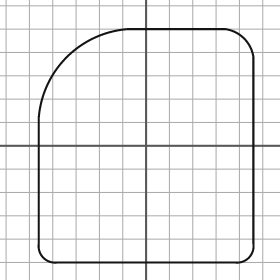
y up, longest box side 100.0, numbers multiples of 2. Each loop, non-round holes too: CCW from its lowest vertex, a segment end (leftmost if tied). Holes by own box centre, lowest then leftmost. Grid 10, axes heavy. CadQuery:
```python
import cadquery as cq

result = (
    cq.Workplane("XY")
    .moveTo(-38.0, -50.0)
    .lineTo(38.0, -50.0)
    .threePointArc((44.0, -48.0), (46.0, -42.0))
    .lineTo(46.0, 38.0)
    .threePointArc((42.0, 46.0), (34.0, 50.0))
    .lineTo(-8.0, 50.0)
    .threePointArc((-34.0, 38.0), (-46.0, 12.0))
    .lineTo(-46.0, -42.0)
    .threePointArc((-44.0, -48.0), (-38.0, -50.0))
    .close()
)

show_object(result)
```